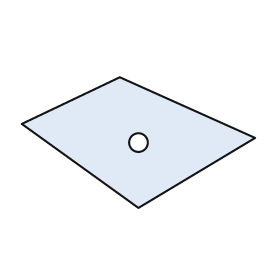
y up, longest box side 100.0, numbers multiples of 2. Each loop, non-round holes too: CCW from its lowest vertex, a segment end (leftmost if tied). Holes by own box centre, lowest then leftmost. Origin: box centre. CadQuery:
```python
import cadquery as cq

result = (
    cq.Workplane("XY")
    .moveTo(0.0, -28.0)
    .lineTo(50.0, 2.0)
    .lineTo(-8.0, 28.0)
    .lineTo(-50.0, 8.0)
    .close()
    .moveTo(0.0, 0.0)
    .circle(4.0)
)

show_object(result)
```